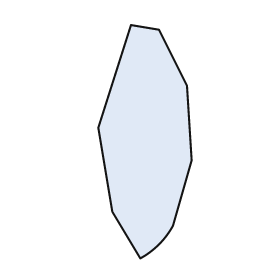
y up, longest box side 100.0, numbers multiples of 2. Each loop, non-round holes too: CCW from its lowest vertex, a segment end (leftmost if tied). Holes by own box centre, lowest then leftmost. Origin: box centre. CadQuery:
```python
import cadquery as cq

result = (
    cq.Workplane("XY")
    .moveTo(-2.0, -50.0)
    .threePointArc((6.0, -44.0), (12.0, -36.0))
    .lineTo(20.0, -8.0)
    .lineTo(18.0, 24.0)
    .lineTo(6.0, 48.0)
    .lineTo(-6.0, 50.0)
    .lineTo(-20.0, 6.0)
    .lineTo(-14.0, -30.0)
    .close()
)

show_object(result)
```